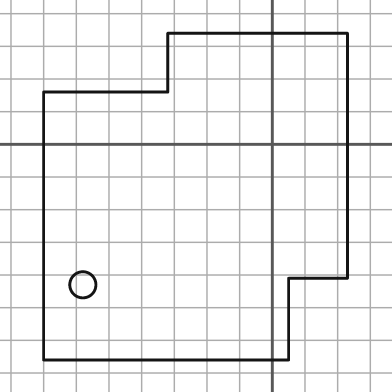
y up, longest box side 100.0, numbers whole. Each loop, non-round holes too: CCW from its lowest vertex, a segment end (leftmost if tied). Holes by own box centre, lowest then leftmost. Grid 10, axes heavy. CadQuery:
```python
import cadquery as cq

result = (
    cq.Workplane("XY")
    .moveTo(-70.0, -66.0)
    .lineTo(5.0, -66.0)
    .lineTo(5.0, -41.0)
    .lineTo(23.0, -41.0)
    .lineTo(23.0, 34.0)
    .lineTo(-32.0, 34.0)
    .lineTo(-32.0, 16.0)
    .lineTo(-70.0, 16.0)
    .close()
    .moveTo(-58.0, -43.0)
    .circle(4.0)
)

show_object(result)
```